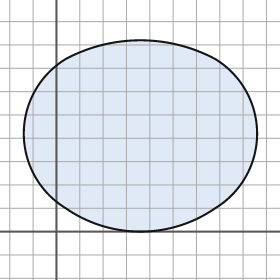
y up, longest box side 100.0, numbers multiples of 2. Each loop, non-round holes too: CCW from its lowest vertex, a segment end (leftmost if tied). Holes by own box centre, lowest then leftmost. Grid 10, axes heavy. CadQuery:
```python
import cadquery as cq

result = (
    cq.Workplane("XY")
    .moveTo(4.0, 10.0)
    .threePointArc((36.0, 0.0), (68.0, 10.0))
    .threePointArc((86.0, 42.0), (68.0, 74.0))
    .threePointArc((36.0, 82.0), (4.0, 74.0))
    .threePointArc((-14.0, 42.0), (4.0, 10.0))
    .close()
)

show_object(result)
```